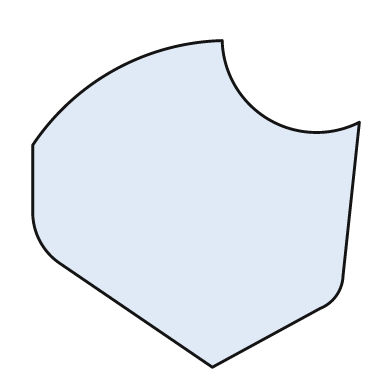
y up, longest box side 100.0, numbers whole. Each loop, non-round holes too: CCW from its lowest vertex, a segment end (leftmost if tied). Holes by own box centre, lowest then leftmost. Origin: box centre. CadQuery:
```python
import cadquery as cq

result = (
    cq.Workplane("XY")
    .moveTo(5.0, -50.0)
    .lineTo(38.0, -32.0)
    .threePointArc((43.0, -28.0), (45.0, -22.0))
    .lineTo(50.0, 25.0)
    .threePointArc((22.0, 26.0), (8.0, 50.0))
    .threePointArc((-25.0, 41.0), (-50.0, 18.0))
    .lineTo(-50.0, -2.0)
    .threePointArc((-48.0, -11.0), (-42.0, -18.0))
    .close()
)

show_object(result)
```